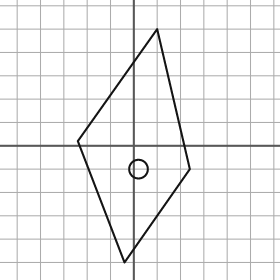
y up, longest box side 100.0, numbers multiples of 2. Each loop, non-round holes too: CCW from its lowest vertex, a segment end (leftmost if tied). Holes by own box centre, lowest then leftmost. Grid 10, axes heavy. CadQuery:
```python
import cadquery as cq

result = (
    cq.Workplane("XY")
    .moveTo(-4.0, -50.0)
    .lineTo(24.0, -10.0)
    .lineTo(10.0, 50.0)
    .lineTo(-24.0, 2.0)
    .close()
    .moveTo(2.0, -10.0)
    .circle(4.0)
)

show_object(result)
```